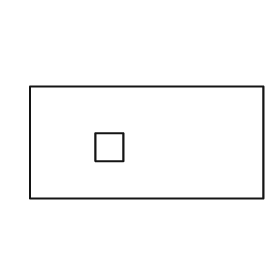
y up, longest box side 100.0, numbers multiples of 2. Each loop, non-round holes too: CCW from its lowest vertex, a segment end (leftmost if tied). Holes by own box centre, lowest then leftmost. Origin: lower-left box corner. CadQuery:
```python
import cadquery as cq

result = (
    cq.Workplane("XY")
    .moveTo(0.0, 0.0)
    .lineTo(100.0, 0.0)
    .lineTo(100.0, 48.0)
    .lineTo(0.0, 48.0)
    .close()
    .moveTo(28.0, 16.0)
    .lineTo(40.0, 16.0)
    .lineTo(40.0, 28.0)
    .lineTo(28.0, 28.0)
    .close()
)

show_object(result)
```